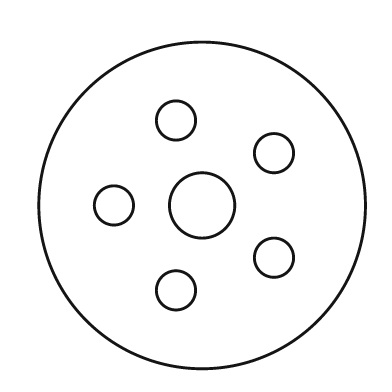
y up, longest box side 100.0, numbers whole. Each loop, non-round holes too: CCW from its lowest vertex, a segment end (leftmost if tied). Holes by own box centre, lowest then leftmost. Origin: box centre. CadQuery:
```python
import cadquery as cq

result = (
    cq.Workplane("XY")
    .moveTo(0.0, 0.0)
    .circle(50.0)
    .moveTo(-8.0, -26.0)
    .circle(6.0)
    .moveTo(22.0, -16.0)
    .circle(6.0)
    .moveTo(-27.0, 0.0)
    .circle(6.0)
    .moveTo(0.0, 0.0)
    .circle(10.0)
    .moveTo(22.0, 16.0)
    .circle(6.0)
    .moveTo(-8.0, 26.0)
    .circle(6.0)
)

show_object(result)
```